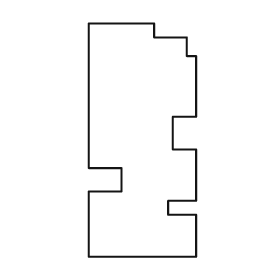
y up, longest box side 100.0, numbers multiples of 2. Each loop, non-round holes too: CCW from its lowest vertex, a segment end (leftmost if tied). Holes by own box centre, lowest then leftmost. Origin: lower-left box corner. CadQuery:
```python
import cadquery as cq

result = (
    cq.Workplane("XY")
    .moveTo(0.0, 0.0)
    .lineTo(46.0, 0.0)
    .lineTo(46.0, 18.0)
    .lineTo(34.0, 18.0)
    .lineTo(34.0, 24.0)
    .lineTo(46.0, 24.0)
    .lineTo(46.0, 46.0)
    .lineTo(36.0, 46.0)
    .lineTo(36.0, 60.0)
    .lineTo(46.0, 60.0)
    .lineTo(46.0, 86.0)
    .lineTo(42.0, 86.0)
    .lineTo(42.0, 94.0)
    .lineTo(28.0, 94.0)
    .lineTo(28.0, 100.0)
    .lineTo(0.0, 100.0)
    .lineTo(0.0, 38.0)
    .lineTo(14.0, 38.0)
    .lineTo(14.0, 28.0)
    .lineTo(0.0, 28.0)
    .close()
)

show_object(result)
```